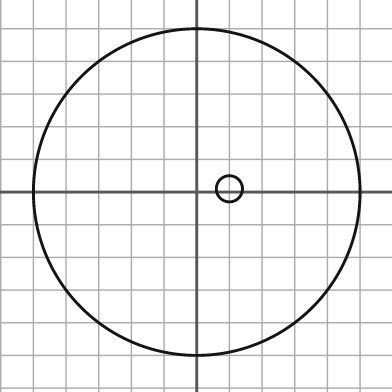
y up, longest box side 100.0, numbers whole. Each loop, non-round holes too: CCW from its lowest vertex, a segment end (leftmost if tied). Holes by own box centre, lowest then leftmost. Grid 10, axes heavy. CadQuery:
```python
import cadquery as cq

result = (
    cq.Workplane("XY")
    .moveTo(0.0, 0.0)
    .circle(50.0)
    .moveTo(10.0, 1.0)
    .circle(4.0)
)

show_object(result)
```